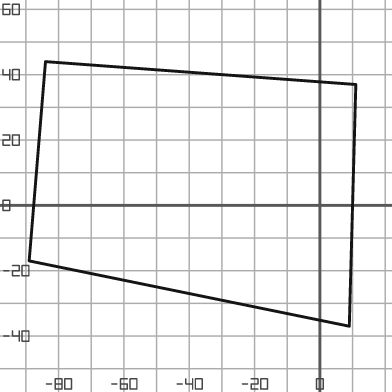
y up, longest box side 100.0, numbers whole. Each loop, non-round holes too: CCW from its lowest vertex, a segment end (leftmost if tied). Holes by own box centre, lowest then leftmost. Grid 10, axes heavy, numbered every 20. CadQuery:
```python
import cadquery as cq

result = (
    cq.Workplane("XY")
    .moveTo(9.0, -37.0)
    .lineTo(11.0, 37.0)
    .lineTo(-84.0, 44.0)
    .lineTo(-89.0, -17.0)
    .close()
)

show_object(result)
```